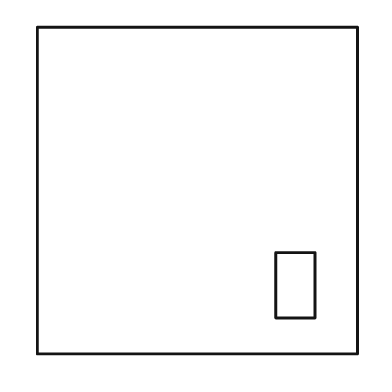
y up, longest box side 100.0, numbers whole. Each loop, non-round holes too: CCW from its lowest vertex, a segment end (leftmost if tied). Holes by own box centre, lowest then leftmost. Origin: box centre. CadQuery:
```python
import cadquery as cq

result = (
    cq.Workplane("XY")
    .moveTo(-49.0, -50.0)
    .lineTo(49.0, -50.0)
    .lineTo(49.0, 50.0)
    .lineTo(-49.0, 50.0)
    .close()
    .moveTo(24.0, -39.0)
    .lineTo(36.0, -39.0)
    .lineTo(36.0, -19.0)
    .lineTo(24.0, -19.0)
    .close()
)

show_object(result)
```